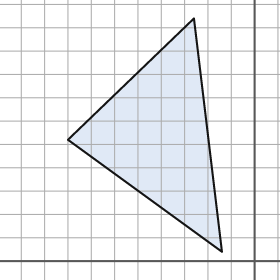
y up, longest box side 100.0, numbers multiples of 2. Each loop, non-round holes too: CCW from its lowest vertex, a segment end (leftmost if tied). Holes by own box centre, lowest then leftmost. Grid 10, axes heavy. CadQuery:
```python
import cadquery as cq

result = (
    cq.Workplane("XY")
    .moveTo(-14.0, 4.0)
    .lineTo(-26.0, 104.0)
    .lineTo(-80.0, 52.0)
    .close()
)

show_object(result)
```